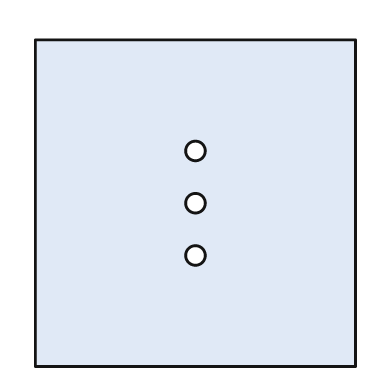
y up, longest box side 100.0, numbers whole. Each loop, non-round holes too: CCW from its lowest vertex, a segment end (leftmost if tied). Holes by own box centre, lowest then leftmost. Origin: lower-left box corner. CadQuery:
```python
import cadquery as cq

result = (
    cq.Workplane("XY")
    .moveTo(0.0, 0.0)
    .lineTo(98.0, 0.0)
    .lineTo(98.0, 100.0)
    .lineTo(0.0, 100.0)
    .close()
    .moveTo(49.0, 34.0)
    .circle(3.0)
    .moveTo(49.0, 50.0)
    .circle(3.0)
    .moveTo(49.0, 66.0)
    .circle(3.0)
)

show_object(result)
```